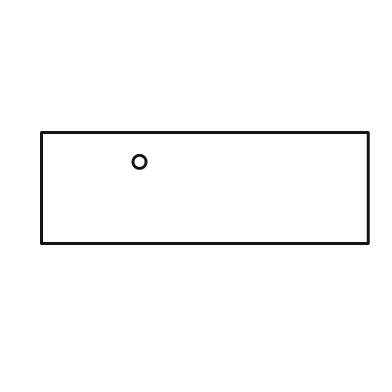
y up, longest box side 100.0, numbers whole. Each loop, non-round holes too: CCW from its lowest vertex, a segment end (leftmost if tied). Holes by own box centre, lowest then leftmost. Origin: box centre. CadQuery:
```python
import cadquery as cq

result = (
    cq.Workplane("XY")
    .moveTo(-50.0, -17.0)
    .lineTo(50.0, -17.0)
    .lineTo(50.0, 17.0)
    .lineTo(-50.0, 17.0)
    .close()
    .moveTo(-20.0, 8.0)
    .circle(2.0)
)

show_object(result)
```